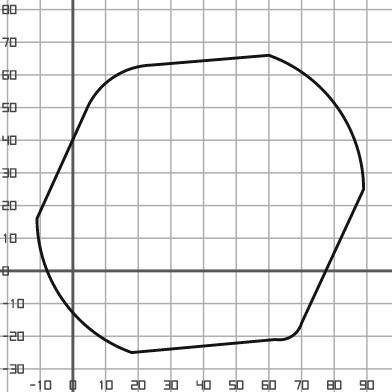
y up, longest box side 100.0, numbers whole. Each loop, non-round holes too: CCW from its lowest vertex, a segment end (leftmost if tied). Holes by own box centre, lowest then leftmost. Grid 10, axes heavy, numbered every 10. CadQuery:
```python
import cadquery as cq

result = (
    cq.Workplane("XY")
    .moveTo(18.0, -25.0)
    .lineTo(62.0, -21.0)
    .threePointArc((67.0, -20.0), (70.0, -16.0))
    .lineTo(89.0, 25.0)
    .threePointArc((81.0, 50.0), (60.0, 66.0))
    .lineTo(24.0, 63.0)
    .threePointArc((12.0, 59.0), (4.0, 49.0))
    .lineTo(-11.0, 16.0)
    .threePointArc((-3.0, -9.0), (18.0, -25.0))
    .close()
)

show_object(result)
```